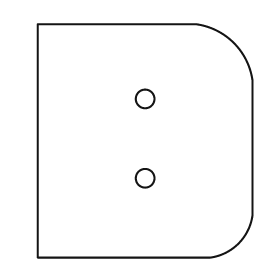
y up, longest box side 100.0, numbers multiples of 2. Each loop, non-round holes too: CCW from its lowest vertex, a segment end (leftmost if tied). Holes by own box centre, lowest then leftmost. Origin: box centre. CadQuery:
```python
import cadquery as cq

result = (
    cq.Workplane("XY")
    .moveTo(-46.0, -50.0)
    .lineTo(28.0, -50.0)
    .threePointArc((40.0, -44.0), (46.0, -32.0))
    .lineTo(46.0, 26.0)
    .threePointArc((38.0, 42.0), (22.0, 50.0))
    .lineTo(-46.0, 50.0)
    .close()
    .moveTo(0.0, -16.0)
    .circle(4.0)
    .moveTo(0.0, 18.0)
    .circle(4.0)
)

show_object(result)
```